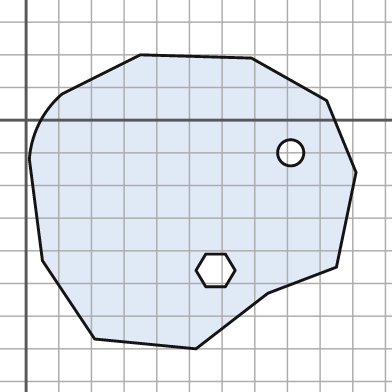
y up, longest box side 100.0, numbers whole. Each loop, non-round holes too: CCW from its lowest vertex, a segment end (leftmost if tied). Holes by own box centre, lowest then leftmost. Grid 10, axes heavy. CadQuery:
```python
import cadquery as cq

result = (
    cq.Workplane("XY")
    .moveTo(52.0, -70.0)
    .lineTo(74.0, -53.0)
    .lineTo(95.0, -45.0)
    .lineTo(101.0, -16.0)
    .lineTo(92.0, 6.0)
    .lineTo(69.0, 19.0)
    .lineTo(35.0, 20.0)
    .lineTo(11.0, 8.0)
    .threePointArc((4.0, -1.0), (1.0, -12.0))
    .lineTo(5.0, -43.0)
    .lineTo(21.0, -67.0)
    .close()
    .moveTo(55.0, -51.0)
    .lineTo(61.0, -51.0)
    .lineTo(64.0, -46.0)
    .lineTo(61.0, -41.0)
    .lineTo(55.0, -41.0)
    .lineTo(52.0, -46.0)
    .close()
    .moveTo(81.0, -10.0)
    .circle(4.0)
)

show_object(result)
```